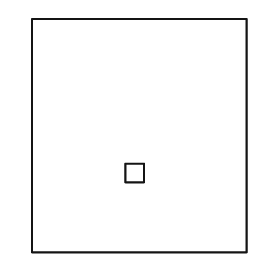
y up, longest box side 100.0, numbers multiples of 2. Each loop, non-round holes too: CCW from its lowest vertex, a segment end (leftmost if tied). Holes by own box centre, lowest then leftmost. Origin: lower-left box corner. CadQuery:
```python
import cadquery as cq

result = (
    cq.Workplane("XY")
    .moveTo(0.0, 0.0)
    .lineTo(92.0, 0.0)
    .lineTo(92.0, 100.0)
    .lineTo(0.0, 100.0)
    .close()
    .moveTo(40.0, 30.0)
    .lineTo(48.0, 30.0)
    .lineTo(48.0, 38.0)
    .lineTo(40.0, 38.0)
    .close()
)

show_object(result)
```